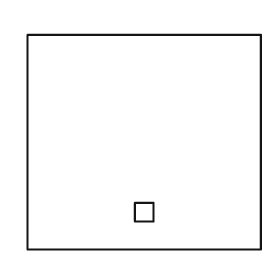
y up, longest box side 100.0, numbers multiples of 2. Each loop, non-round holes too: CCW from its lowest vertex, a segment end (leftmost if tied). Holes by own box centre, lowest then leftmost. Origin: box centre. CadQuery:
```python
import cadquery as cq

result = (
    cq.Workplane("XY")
    .moveTo(-50.0, -46.0)
    .lineTo(50.0, -46.0)
    .lineTo(50.0, 46.0)
    .lineTo(-50.0, 46.0)
    .close()
    .moveTo(-4.0, -34.0)
    .lineTo(4.0, -34.0)
    .lineTo(4.0, -26.0)
    .lineTo(-4.0, -26.0)
    .close()
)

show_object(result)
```